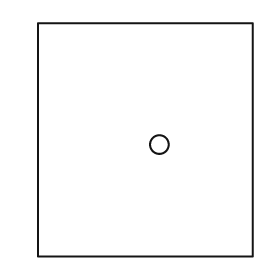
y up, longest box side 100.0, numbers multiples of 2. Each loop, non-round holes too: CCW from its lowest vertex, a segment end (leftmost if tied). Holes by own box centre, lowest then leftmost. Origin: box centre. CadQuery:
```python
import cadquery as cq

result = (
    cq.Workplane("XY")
    .moveTo(-46.0, -50.0)
    .lineTo(46.0, -50.0)
    .lineTo(46.0, 50.0)
    .lineTo(-46.0, 50.0)
    .close()
    .moveTo(6.0, -2.0)
    .circle(4.0)
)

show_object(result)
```